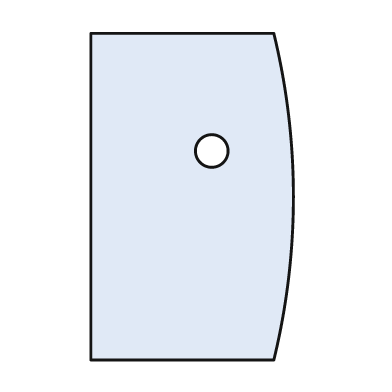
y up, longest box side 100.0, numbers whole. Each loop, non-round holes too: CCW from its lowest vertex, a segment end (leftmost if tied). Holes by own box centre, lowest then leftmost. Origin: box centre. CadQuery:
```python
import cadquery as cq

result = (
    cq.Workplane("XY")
    .moveTo(-31.0, -50.0)
    .lineTo(25.0, -50.0)
    .threePointArc((31.0, 0.0), (25.0, 50.0))
    .lineTo(-31.0, 50.0)
    .close()
    .moveTo(6.0, 14.0)
    .circle(5.0)
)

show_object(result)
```